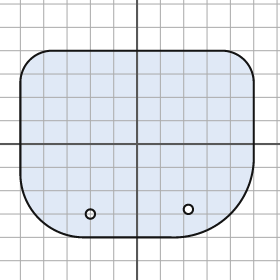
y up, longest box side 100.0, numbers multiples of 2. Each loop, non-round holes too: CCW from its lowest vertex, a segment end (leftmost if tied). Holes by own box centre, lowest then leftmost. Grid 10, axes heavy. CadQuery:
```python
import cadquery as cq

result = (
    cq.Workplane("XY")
    .moveTo(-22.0, -40.0)
    .lineTo(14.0, -40.0)
    .threePointArc((40.0, -30.0), (50.0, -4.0))
    .lineTo(50.0, 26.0)
    .threePointArc((46.0, 36.0), (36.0, 40.0))
    .lineTo(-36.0, 40.0)
    .threePointArc((-46.0, 36.0), (-50.0, 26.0))
    .lineTo(-50.0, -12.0)
    .threePointArc((-42.0, -32.0), (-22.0, -40.0))
    .close()
    .moveTo(-20.0, -30.0)
    .circle(2.0)
    .moveTo(22.0, -28.0)
    .circle(2.0)
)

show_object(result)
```